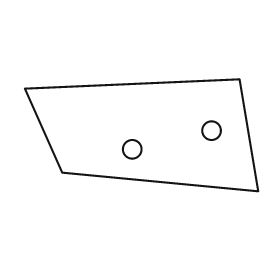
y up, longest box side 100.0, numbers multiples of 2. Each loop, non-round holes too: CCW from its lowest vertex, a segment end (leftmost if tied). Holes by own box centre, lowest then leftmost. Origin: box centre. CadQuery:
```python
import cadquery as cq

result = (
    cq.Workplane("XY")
    .moveTo(50.0, -24.0)
    .lineTo(42.0, 24.0)
    .lineTo(-50.0, 20.0)
    .lineTo(-34.0, -16.0)
    .close()
    .moveTo(-4.0, -6.0)
    .circle(4.0)
    .moveTo(30.0, 2.0)
    .circle(4.0)
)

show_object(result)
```